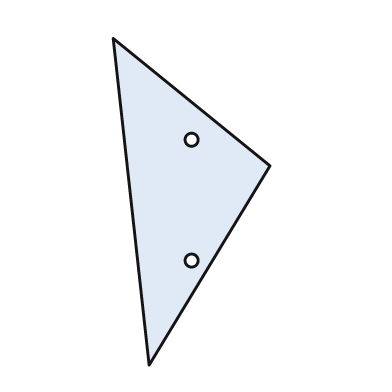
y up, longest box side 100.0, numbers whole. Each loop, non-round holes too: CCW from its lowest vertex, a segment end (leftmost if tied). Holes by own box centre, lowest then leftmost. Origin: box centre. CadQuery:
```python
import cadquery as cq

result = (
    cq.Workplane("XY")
    .moveTo(-13.0, -50.0)
    .lineTo(24.0, 11.0)
    .lineTo(-24.0, 50.0)
    .close()
    .moveTo(0.0, -18.0)
    .circle(2.0)
    .moveTo(0.0, 19.0)
    .circle(2.0)
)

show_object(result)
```